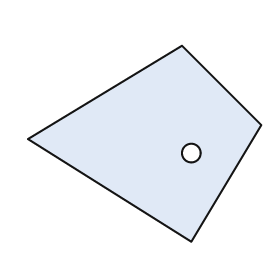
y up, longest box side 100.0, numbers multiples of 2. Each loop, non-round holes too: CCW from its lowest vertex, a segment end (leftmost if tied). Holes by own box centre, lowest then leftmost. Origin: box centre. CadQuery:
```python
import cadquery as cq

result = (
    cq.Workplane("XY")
    .moveTo(20.0, -42.0)
    .lineTo(50.0, 8.0)
    .lineTo(16.0, 42.0)
    .lineTo(-50.0, 2.0)
    .close()
    .moveTo(20.0, -4.0)
    .circle(4.0)
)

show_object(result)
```